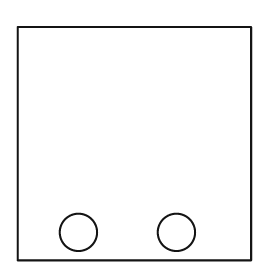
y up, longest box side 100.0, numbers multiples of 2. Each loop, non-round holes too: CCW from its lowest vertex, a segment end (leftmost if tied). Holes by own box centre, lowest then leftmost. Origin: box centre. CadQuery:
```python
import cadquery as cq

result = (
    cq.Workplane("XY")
    .moveTo(-50.0, -50.0)
    .lineTo(50.0, -50.0)
    .lineTo(50.0, 50.0)
    .lineTo(-50.0, 50.0)
    .close()
    .moveTo(-24.0, -38.0)
    .circle(8.0)
    .moveTo(18.0, -38.0)
    .circle(8.0)
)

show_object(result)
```